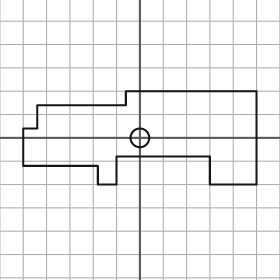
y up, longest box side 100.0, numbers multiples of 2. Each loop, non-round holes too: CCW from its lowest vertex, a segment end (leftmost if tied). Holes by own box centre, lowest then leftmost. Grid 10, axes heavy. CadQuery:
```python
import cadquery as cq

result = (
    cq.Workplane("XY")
    .moveTo(-18.0, -20.0)
    .lineTo(-10.0, -20.0)
    .lineTo(-10.0, -8.0)
    .lineTo(30.0, -8.0)
    .lineTo(30.0, -20.0)
    .lineTo(50.0, -20.0)
    .lineTo(50.0, 20.0)
    .lineTo(-6.0, 20.0)
    .lineTo(-6.0, 14.0)
    .lineTo(-44.0, 14.0)
    .lineTo(-44.0, 4.0)
    .lineTo(-50.0, 4.0)
    .lineTo(-50.0, -12.0)
    .lineTo(-18.0, -12.0)
    .close()
    .moveTo(0.0, 0.0)
    .circle(4.0)
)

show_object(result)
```